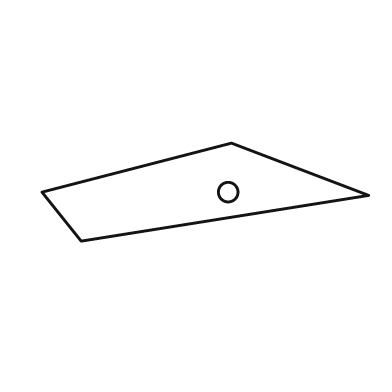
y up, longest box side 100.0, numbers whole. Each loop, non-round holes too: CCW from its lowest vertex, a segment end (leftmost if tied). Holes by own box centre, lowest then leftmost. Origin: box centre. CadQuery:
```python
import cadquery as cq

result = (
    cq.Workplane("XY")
    .moveTo(-38.0, -15.0)
    .lineTo(50.0, -1.0)
    .lineTo(8.0, 15.0)
    .lineTo(-50.0, 0.0)
    .close()
    .moveTo(7.0, 0.0)
    .circle(3.0)
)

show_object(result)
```